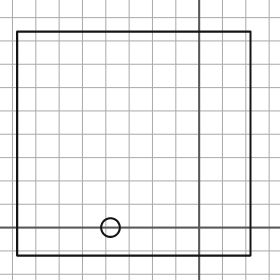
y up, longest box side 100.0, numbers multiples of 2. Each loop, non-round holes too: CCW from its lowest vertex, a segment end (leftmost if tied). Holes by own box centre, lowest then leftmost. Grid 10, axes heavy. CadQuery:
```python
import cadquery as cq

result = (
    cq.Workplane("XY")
    .moveTo(-78.0, -12.0)
    .lineTo(22.0, -12.0)
    .lineTo(22.0, 84.0)
    .lineTo(-78.0, 84.0)
    .close()
    .moveTo(-38.0, 0.0)
    .circle(4.0)
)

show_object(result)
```